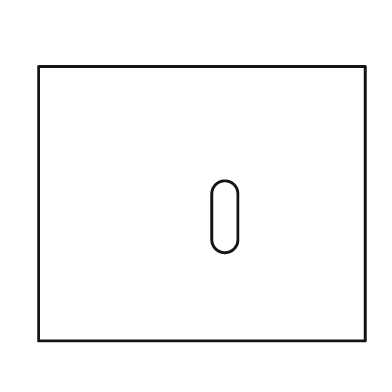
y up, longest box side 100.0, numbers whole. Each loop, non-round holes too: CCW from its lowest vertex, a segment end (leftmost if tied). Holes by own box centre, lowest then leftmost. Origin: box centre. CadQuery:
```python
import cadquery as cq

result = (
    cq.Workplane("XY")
    .moveTo(-50.0, -42.0)
    .lineTo(50.0, -42.0)
    .lineTo(50.0, 42.0)
    .lineTo(-50.0, 42.0)
    .close()
    .moveTo(3.0, -11.0)
    .threePointArc((7.0, -15.0), (11.0, -11.0))
    .lineTo(11.0, 3.0)
    .threePointArc((7.0, 7.0), (3.0, 3.0))
    .close()
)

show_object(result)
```